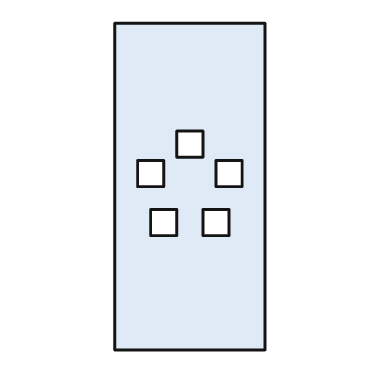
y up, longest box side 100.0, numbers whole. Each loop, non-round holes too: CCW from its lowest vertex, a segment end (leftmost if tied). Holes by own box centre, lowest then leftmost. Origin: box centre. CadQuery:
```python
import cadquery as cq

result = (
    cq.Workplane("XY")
    .moveTo(-23.0, -50.0)
    .lineTo(23.0, -50.0)
    .lineTo(23.0, 50.0)
    .lineTo(-23.0, 50.0)
    .close()
    .moveTo(-12.0, -15.0)
    .lineTo(-4.0, -15.0)
    .lineTo(-4.0, -7.0)
    .lineTo(-12.0, -7.0)
    .close()
    .moveTo(4.0, -15.0)
    .lineTo(12.0, -15.0)
    .lineTo(12.0, -7.0)
    .lineTo(4.0, -7.0)
    .close()
    .moveTo(-16.0, 0.0)
    .lineTo(-8.0, 0.0)
    .lineTo(-8.0, 8.0)
    .lineTo(-16.0, 8.0)
    .close()
    .moveTo(8.0, 0.0)
    .lineTo(16.0, 0.0)
    .lineTo(16.0, 8.0)
    .lineTo(8.0, 8.0)
    .close()
    .moveTo(-4.0, 9.0)
    .lineTo(4.0, 9.0)
    .lineTo(4.0, 17.0)
    .lineTo(-4.0, 17.0)
    .close()
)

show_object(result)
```